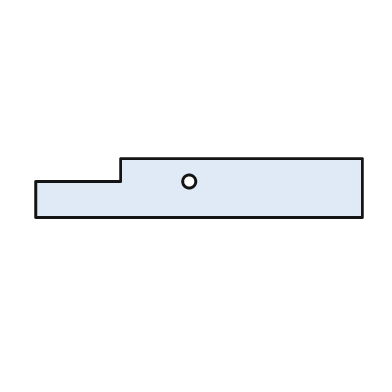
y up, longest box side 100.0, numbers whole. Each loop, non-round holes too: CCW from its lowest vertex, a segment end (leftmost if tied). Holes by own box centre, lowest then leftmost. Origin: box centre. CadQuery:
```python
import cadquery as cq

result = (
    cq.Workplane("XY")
    .moveTo(-50.0, -9.0)
    .lineTo(50.0, -9.0)
    .lineTo(50.0, 9.0)
    .lineTo(-24.0, 9.0)
    .lineTo(-24.0, 2.0)
    .lineTo(-50.0, 2.0)
    .close()
    .moveTo(-3.0, 2.0)
    .circle(2.0)
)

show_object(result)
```